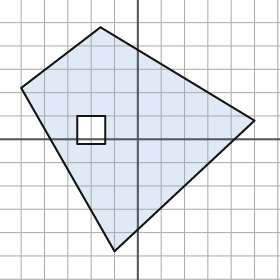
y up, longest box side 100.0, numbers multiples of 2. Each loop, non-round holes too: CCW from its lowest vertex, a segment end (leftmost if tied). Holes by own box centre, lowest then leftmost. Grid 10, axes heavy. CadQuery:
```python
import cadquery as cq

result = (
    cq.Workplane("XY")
    .moveTo(-10.0, -48.0)
    .lineTo(50.0, 8.0)
    .lineTo(-16.0, 48.0)
    .lineTo(-50.0, 22.0)
    .close()
    .moveTo(-26.0, -2.0)
    .lineTo(-14.0, -2.0)
    .lineTo(-14.0, 10.0)
    .lineTo(-26.0, 10.0)
    .close()
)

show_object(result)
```